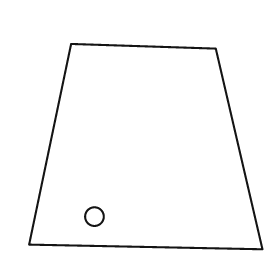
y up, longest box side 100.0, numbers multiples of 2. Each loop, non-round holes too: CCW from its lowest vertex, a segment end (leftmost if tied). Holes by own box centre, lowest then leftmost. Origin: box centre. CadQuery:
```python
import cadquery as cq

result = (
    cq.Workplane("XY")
    .moveTo(50.0, -44.0)
    .lineTo(30.0, 42.0)
    .lineTo(-32.0, 44.0)
    .lineTo(-50.0, -42.0)
    .close()
    .moveTo(-22.0, -30.0)
    .circle(4.0)
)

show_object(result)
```